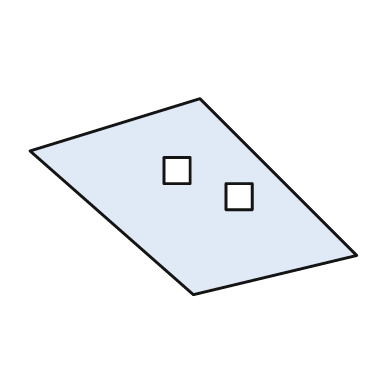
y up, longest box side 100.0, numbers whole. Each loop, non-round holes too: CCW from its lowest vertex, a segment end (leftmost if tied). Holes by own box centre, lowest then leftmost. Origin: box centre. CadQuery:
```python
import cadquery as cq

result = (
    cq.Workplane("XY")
    .moveTo(0.0, -30.0)
    .lineTo(50.0, -18.0)
    .lineTo(2.0, 30.0)
    .lineTo(-50.0, 14.0)
    .close()
    .moveTo(10.0, -4.0)
    .lineTo(18.0, -4.0)
    .lineTo(18.0, 4.0)
    .lineTo(10.0, 4.0)
    .close()
    .moveTo(-9.0, 4.0)
    .lineTo(-1.0, 4.0)
    .lineTo(-1.0, 12.0)
    .lineTo(-9.0, 12.0)
    .close()
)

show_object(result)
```